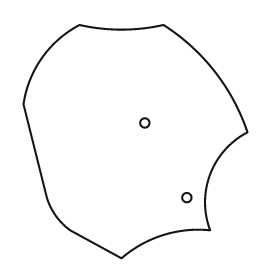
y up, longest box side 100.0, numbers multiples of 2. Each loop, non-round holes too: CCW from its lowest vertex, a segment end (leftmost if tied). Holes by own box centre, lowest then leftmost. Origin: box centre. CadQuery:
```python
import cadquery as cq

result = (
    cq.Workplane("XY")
    .moveTo(-6.0, -50.0)
    .threePointArc((12.0, -40.0), (32.0, -38.0))
    .threePointArc((32.0, -14.0), (48.0, 4.0))
    .threePointArc((34.0, 30.0), (12.0, 50.0))
    .threePointArc((-6.0, 48.0), (-24.0, 50.0))
    .threePointArc((-40.0, 36.0), (-48.0, 16.0))
    .lineTo(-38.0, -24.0)
    .threePointArc((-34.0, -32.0), (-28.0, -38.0))
    .close()
    .moveTo(22.0, -24.0)
    .circle(2.0)
    .moveTo(4.0, 8.0)
    .circle(2.0)
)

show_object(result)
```